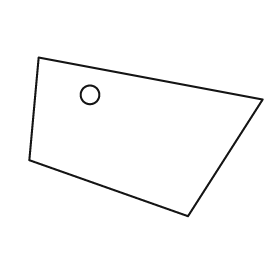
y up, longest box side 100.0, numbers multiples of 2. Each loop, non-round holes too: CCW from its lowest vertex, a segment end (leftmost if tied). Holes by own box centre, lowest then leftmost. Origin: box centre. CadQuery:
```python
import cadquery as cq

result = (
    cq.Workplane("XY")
    .moveTo(18.0, -34.0)
    .lineTo(50.0, 16.0)
    .lineTo(-46.0, 34.0)
    .lineTo(-50.0, -10.0)
    .close()
    .moveTo(-24.0, 18.0)
    .circle(4.0)
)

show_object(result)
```